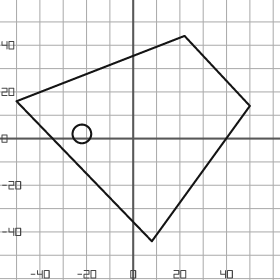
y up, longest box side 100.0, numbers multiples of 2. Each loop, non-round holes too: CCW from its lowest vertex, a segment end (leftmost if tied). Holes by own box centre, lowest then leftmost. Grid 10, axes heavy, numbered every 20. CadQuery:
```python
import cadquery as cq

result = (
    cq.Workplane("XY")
    .moveTo(8.0, -44.0)
    .lineTo(50.0, 14.0)
    .lineTo(22.0, 44.0)
    .lineTo(-50.0, 16.0)
    .close()
    .moveTo(-22.0, 2.0)
    .circle(4.0)
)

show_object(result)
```